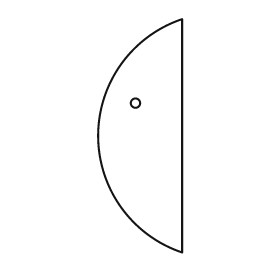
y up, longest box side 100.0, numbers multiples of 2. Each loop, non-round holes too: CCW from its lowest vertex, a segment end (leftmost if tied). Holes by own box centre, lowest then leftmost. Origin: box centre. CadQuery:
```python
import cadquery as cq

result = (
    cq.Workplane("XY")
    .moveTo(18.0, -50.0)
    .lineTo(18.0, 50.0)
    .threePointArc((-18.0, 0.0), (18.0, -50.0))
    .close()
    .moveTo(-2.0, 14.0)
    .circle(2.0)
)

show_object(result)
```